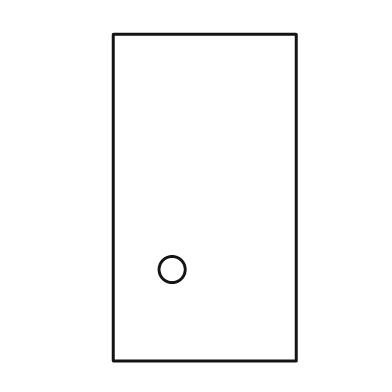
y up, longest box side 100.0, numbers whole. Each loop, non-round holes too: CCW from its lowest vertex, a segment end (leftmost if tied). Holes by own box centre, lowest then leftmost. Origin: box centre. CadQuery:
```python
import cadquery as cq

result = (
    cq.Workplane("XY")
    .moveTo(-28.0, -50.0)
    .lineTo(28.0, -50.0)
    .lineTo(28.0, 50.0)
    .lineTo(-28.0, 50.0)
    .close()
    .moveTo(-10.0, -22.0)
    .circle(4.0)
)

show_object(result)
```